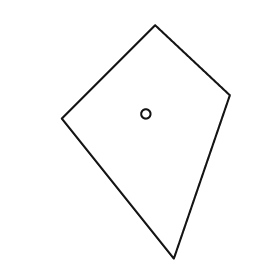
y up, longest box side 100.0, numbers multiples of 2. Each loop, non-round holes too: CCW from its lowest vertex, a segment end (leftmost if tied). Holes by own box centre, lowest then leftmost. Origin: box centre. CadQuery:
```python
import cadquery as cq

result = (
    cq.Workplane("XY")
    .moveTo(12.0, -50.0)
    .lineTo(36.0, 20.0)
    .lineTo(4.0, 50.0)
    .lineTo(-36.0, 10.0)
    .close()
    .moveTo(0.0, 12.0)
    .circle(2.0)
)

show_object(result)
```